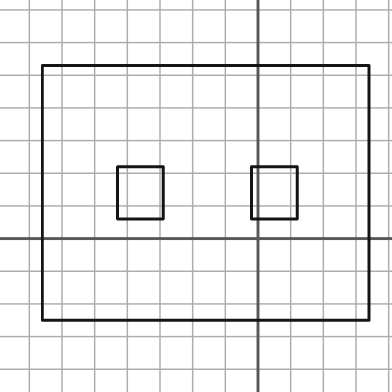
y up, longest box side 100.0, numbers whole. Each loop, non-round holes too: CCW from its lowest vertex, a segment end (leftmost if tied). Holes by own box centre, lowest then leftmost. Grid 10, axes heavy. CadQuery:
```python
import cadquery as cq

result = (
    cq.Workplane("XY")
    .moveTo(-66.0, -25.0)
    .lineTo(34.0, -25.0)
    .lineTo(34.0, 53.0)
    .lineTo(-66.0, 53.0)
    .close()
    .moveTo(-43.0, 6.0)
    .lineTo(-29.0, 6.0)
    .lineTo(-29.0, 22.0)
    .lineTo(-43.0, 22.0)
    .close()
    .moveTo(-2.0, 6.0)
    .lineTo(12.0, 6.0)
    .lineTo(12.0, 22.0)
    .lineTo(-2.0, 22.0)
    .close()
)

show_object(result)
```